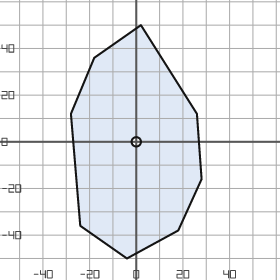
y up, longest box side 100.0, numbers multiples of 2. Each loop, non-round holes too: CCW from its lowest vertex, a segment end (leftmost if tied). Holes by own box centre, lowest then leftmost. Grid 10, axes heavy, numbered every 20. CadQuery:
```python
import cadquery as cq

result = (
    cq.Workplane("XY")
    .moveTo(-4.0, -50.0)
    .lineTo(18.0, -38.0)
    .lineTo(28.0, -16.0)
    .lineTo(26.0, 12.0)
    .lineTo(2.0, 50.0)
    .lineTo(-18.0, 36.0)
    .lineTo(-28.0, 12.0)
    .lineTo(-24.0, -36.0)
    .close()
    .moveTo(0.0, 0.0)
    .circle(2.0)
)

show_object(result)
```